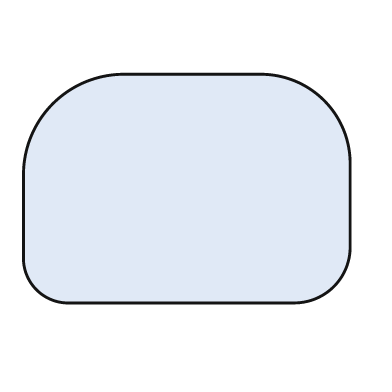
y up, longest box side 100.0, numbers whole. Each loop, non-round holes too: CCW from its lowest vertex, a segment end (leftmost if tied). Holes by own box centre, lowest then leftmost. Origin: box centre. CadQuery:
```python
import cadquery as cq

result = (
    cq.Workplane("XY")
    .moveTo(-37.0, -35.0)
    .lineTo(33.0, -35.0)
    .threePointArc((45.0, -30.0), (50.0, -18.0))
    .lineTo(50.0, 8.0)
    .threePointArc((42.0, 27.0), (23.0, 35.0))
    .lineTo(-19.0, 35.0)
    .threePointArc((-41.0, 26.0), (-50.0, 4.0))
    .lineTo(-50.0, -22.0)
    .threePointArc((-46.0, -31.0), (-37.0, -35.0))
    .close()
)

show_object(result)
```